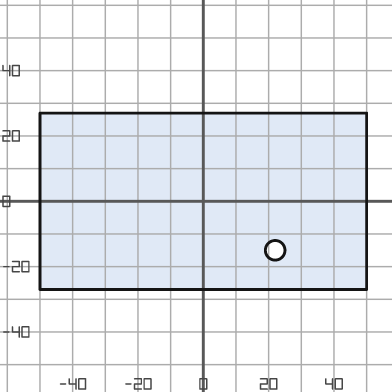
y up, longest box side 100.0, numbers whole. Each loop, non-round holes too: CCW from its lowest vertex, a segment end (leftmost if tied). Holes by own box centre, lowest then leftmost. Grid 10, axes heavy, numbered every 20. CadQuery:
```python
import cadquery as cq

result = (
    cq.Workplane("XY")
    .moveTo(-50.0, -27.0)
    .lineTo(50.0, -27.0)
    .lineTo(50.0, 27.0)
    .lineTo(-50.0, 27.0)
    .close()
    .moveTo(22.0, -15.0)
    .circle(3.0)
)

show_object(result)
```